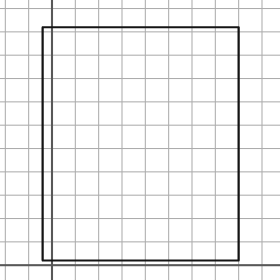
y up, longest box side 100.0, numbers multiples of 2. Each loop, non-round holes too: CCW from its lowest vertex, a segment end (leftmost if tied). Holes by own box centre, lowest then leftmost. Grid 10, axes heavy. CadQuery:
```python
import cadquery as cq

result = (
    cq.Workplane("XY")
    .moveTo(-4.0, 2.0)
    .lineTo(80.0, 2.0)
    .lineTo(80.0, 102.0)
    .lineTo(-4.0, 102.0)
    .close()
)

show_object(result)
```